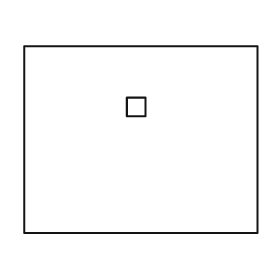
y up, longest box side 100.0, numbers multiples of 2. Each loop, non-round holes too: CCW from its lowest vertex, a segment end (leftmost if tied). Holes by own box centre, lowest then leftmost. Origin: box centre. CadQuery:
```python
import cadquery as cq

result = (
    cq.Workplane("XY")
    .moveTo(-50.0, -40.0)
    .lineTo(50.0, -40.0)
    .lineTo(50.0, 40.0)
    .lineTo(-50.0, 40.0)
    .close()
    .moveTo(-6.0, 10.0)
    .lineTo(2.0, 10.0)
    .lineTo(2.0, 18.0)
    .lineTo(-6.0, 18.0)
    .close()
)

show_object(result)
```